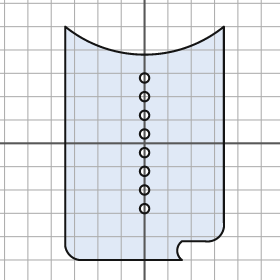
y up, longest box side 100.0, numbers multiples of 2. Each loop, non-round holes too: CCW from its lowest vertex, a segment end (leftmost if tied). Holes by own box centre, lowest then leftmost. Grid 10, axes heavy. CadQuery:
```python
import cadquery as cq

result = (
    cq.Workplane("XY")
    .moveTo(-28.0, -50.0)
    .lineTo(16.0, -50.0)
    .threePointArc((14.0, -46.0), (16.0, -42.0))
    .lineTo(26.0, -42.0)
    .threePointArc((32.0, -40.0), (34.0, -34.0))
    .lineTo(34.0, 50.0)
    .threePointArc((0.0, 38.0), (-34.0, 50.0))
    .lineTo(-34.0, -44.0)
    .threePointArc((-32.0, -48.0), (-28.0, -50.0))
    .close()
    .moveTo(0.0, -28.0)
    .circle(2.0)
    .moveTo(0.0, -20.0)
    .circle(2.0)
    .moveTo(0.0, -12.0)
    .circle(2.0)
    .moveTo(0.0, -4.0)
    .circle(2.0)
    .moveTo(0.0, 4.0)
    .circle(2.0)
    .moveTo(0.0, 12.0)
    .circle(2.0)
    .moveTo(0.0, 20.0)
    .circle(2.0)
    .moveTo(0.0, 28.0)
    .circle(2.0)
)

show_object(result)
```